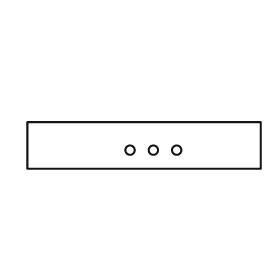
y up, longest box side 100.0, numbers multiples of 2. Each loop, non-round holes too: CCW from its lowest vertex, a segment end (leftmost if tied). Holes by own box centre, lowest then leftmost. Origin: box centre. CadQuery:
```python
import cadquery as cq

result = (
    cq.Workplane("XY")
    .moveTo(-50.0, -10.0)
    .lineTo(50.0, -10.0)
    .lineTo(50.0, 10.0)
    .lineTo(-50.0, 10.0)
    .close()
    .moveTo(-6.0, -2.0)
    .circle(2.0)
    .moveTo(4.0, -2.0)
    .circle(2.0)
    .moveTo(14.0, -2.0)
    .circle(2.0)
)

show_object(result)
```